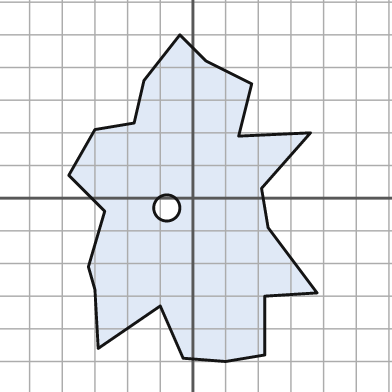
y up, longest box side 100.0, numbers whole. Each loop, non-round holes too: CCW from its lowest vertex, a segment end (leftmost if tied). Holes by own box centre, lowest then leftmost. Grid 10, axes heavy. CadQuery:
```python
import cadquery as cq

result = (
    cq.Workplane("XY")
    .moveTo(10.0, -50.0)
    .lineTo(22.0, -48.0)
    .lineTo(22.0, -30.0)
    .lineTo(38.0, -29.0)
    .lineTo(23.0, -9.0)
    .lineTo(21.0, 3.0)
    .lineTo(36.0, 20.0)
    .lineTo(14.0, 19.0)
    .lineTo(18.0, 35.0)
    .lineTo(4.0, 42.0)
    .lineTo(-4.0, 50.0)
    .lineTo(-15.0, 36.0)
    .lineTo(-18.0, 23.0)
    .lineTo(-30.0, 21.0)
    .lineTo(-38.0, 7.0)
    .lineTo(-27.0, -4.0)
    .lineTo(-32.0, -21.0)
    .lineTo(-30.0, -28.0)
    .lineTo(-29.0, -46.0)
    .lineTo(-10.0, -33.0)
    .lineTo(-3.0, -49.0)
    .close()
    .moveTo(-8.0, -3.0)
    .circle(4.0)
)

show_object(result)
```